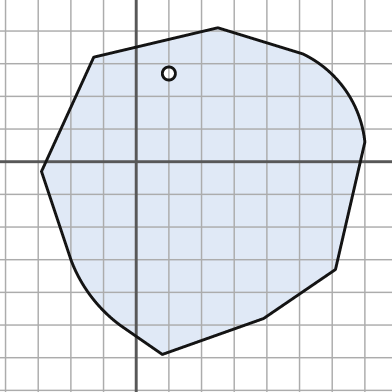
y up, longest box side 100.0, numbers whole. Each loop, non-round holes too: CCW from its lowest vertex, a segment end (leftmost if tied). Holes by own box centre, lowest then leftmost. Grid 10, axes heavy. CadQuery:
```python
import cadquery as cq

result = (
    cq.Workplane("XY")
    .moveTo(8.0, -59.0)
    .lineTo(39.0, -48.0)
    .lineTo(61.0, -33.0)
    .lineTo(70.0, 6.0)
    .threePointArc((64.0, 22.0), (51.0, 33.0))
    .lineTo(25.0, 41.0)
    .lineTo(-13.0, 32.0)
    .lineTo(-29.0, -3.0)
    .lineTo(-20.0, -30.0)
    .threePointArc((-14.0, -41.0), (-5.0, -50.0))
    .close()
    .moveTo(10.0, 27.0)
    .circle(2.0)
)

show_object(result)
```